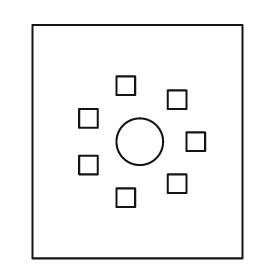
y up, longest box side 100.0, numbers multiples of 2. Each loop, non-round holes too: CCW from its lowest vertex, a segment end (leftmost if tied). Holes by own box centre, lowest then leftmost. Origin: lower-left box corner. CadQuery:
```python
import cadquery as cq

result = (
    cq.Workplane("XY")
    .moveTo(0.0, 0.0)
    .lineTo(90.0, 0.0)
    .lineTo(90.0, 100.0)
    .lineTo(0.0, 100.0)
    .close()
    .moveTo(36.0, 22.0)
    .lineTo(44.0, 22.0)
    .lineTo(44.0, 30.0)
    .lineTo(36.0, 30.0)
    .close()
    .moveTo(58.0, 28.0)
    .lineTo(66.0, 28.0)
    .lineTo(66.0, 36.0)
    .lineTo(58.0, 36.0)
    .close()
    .moveTo(20.0, 36.0)
    .lineTo(28.0, 36.0)
    .lineTo(28.0, 44.0)
    .lineTo(20.0, 44.0)
    .close()
    .moveTo(46.0, 50.0)
    .circle(10.0)
    .moveTo(66.0, 46.0)
    .lineTo(74.0, 46.0)
    .lineTo(74.0, 54.0)
    .lineTo(66.0, 54.0)
    .close()
    .moveTo(20.0, 56.0)
    .lineTo(28.0, 56.0)
    .lineTo(28.0, 64.0)
    .lineTo(20.0, 64.0)
    .close()
    .moveTo(58.0, 64.0)
    .lineTo(66.0, 64.0)
    .lineTo(66.0, 72.0)
    .lineTo(58.0, 72.0)
    .close()
    .moveTo(36.0, 70.0)
    .lineTo(44.0, 70.0)
    .lineTo(44.0, 78.0)
    .lineTo(36.0, 78.0)
    .close()
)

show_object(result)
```